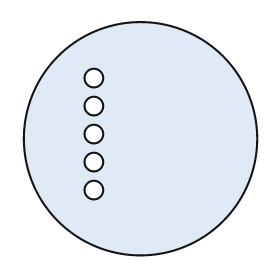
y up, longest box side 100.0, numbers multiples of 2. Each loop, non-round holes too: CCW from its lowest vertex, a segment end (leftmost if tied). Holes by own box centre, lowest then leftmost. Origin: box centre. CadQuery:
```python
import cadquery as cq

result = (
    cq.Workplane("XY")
    .moveTo(0.0, 0.0)
    .circle(50.0)
    .moveTo(-20.0, -22.0)
    .circle(4.0)
    .moveTo(-20.0, -10.0)
    .circle(4.0)
    .moveTo(-20.0, 2.0)
    .circle(4.0)
    .moveTo(-20.0, 14.0)
    .circle(4.0)
    .moveTo(-20.0, 26.0)
    .circle(4.0)
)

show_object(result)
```